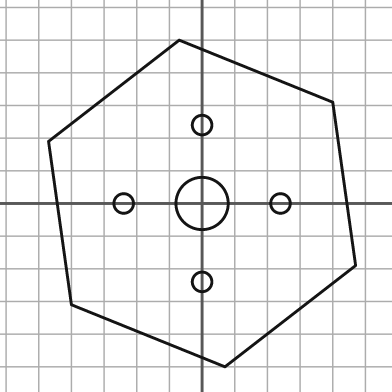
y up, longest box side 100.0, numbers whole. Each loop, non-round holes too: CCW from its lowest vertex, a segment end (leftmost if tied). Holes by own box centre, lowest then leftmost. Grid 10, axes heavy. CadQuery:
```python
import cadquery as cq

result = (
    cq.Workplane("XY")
    .moveTo(7.0, -50.0)
    .lineTo(47.0, -19.0)
    .lineTo(40.0, 31.0)
    .lineTo(-7.0, 50.0)
    .lineTo(-47.0, 19.0)
    .lineTo(-40.0, -31.0)
    .close()
    .moveTo(0.0, -24.0)
    .circle(3.0)
    .moveTo(-24.0, 0.0)
    .circle(3.0)
    .moveTo(0.0, 0.0)
    .circle(8.0)
    .moveTo(24.0, 0.0)
    .circle(3.0)
    .moveTo(0.0, 24.0)
    .circle(3.0)
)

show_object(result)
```